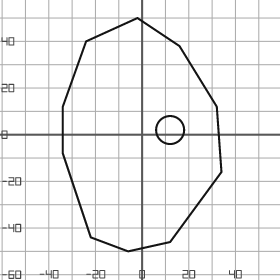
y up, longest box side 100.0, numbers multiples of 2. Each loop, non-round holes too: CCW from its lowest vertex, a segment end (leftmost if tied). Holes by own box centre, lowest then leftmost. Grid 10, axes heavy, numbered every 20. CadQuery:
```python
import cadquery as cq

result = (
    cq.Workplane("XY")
    .moveTo(-6.0, -50.0)
    .lineTo(12.0, -46.0)
    .lineTo(34.0, -16.0)
    .lineTo(32.0, 12.0)
    .lineTo(16.0, 38.0)
    .lineTo(-2.0, 50.0)
    .lineTo(-24.0, 40.0)
    .lineTo(-34.0, 12.0)
    .lineTo(-34.0, -8.0)
    .lineTo(-22.0, -44.0)
    .close()
    .moveTo(12.0, 2.0)
    .circle(6.0)
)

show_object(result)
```